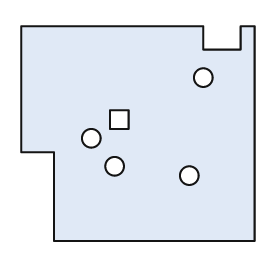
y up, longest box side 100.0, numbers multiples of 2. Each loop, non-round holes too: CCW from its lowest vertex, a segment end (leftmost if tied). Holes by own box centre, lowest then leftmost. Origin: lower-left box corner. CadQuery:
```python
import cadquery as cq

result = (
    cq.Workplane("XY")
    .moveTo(14.0, 0.0)
    .lineTo(100.0, 0.0)
    .lineTo(100.0, 92.0)
    .lineTo(94.0, 92.0)
    .lineTo(94.0, 82.0)
    .lineTo(78.0, 82.0)
    .lineTo(78.0, 92.0)
    .lineTo(0.0, 92.0)
    .lineTo(0.0, 38.0)
    .lineTo(14.0, 38.0)
    .close()
    .moveTo(72.0, 28.0)
    .circle(4.0)
    .moveTo(40.0, 32.0)
    .circle(4.0)
    .moveTo(30.0, 44.0)
    .circle(4.0)
    .moveTo(38.0, 48.0)
    .lineTo(46.0, 48.0)
    .lineTo(46.0, 56.0)
    .lineTo(38.0, 56.0)
    .close()
    .moveTo(78.0, 70.0)
    .circle(4.0)
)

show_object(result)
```